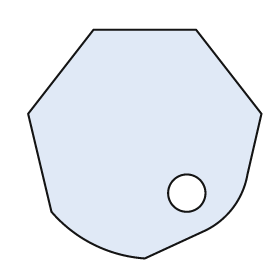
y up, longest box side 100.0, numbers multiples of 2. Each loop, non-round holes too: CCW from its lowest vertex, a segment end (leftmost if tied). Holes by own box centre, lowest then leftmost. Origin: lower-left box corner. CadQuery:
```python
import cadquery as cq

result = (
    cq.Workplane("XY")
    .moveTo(50.0, 0.0)
    .lineTo(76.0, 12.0)
    .threePointArc((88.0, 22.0), (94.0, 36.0))
    .lineTo(100.0, 62.0)
    .lineTo(72.0, 98.0)
    .lineTo(28.0, 98.0)
    .lineTo(0.0, 62.0)
    .lineTo(10.0, 20.0)
    .threePointArc((28.0, 6.0), (50.0, 0.0))
    .close()
    .moveTo(68.0, 28.0)
    .circle(8.0)
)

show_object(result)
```